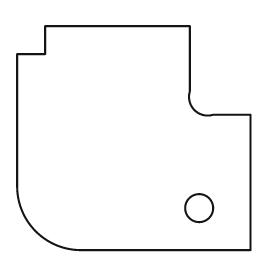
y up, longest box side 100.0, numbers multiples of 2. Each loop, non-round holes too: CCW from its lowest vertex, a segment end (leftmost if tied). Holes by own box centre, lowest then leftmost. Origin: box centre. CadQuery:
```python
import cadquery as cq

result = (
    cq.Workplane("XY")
    .moveTo(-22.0, -48.0)
    .lineTo(50.0, -48.0)
    .lineTo(50.0, 10.0)
    .lineTo(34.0, 10.0)
    .threePointArc((26.0, 12.0), (24.0, 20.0))
    .lineTo(24.0, 48.0)
    .lineTo(-38.0, 48.0)
    .lineTo(-38.0, 36.0)
    .lineTo(-50.0, 36.0)
    .lineTo(-50.0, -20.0)
    .threePointArc((-42.0, -40.0), (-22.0, -48.0))
    .close()
    .moveTo(28.0, -30.0)
    .circle(6.0)
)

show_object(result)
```